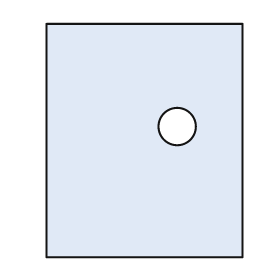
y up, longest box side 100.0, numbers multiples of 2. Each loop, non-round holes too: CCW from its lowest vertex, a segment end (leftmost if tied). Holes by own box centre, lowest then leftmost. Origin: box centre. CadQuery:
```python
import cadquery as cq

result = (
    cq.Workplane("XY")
    .moveTo(-42.0, -50.0)
    .lineTo(42.0, -50.0)
    .lineTo(42.0, 50.0)
    .lineTo(-42.0, 50.0)
    .close()
    .moveTo(14.0, 6.0)
    .circle(8.0)
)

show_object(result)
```